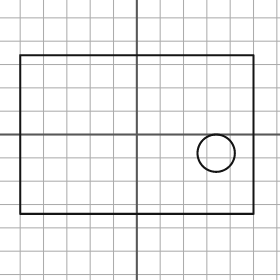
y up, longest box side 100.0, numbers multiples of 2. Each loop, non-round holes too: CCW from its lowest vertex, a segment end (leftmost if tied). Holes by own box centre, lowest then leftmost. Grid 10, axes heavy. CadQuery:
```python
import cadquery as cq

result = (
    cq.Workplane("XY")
    .moveTo(-50.0, -34.0)
    .lineTo(50.0, -34.0)
    .lineTo(50.0, 34.0)
    .lineTo(-50.0, 34.0)
    .close()
    .moveTo(34.0, -8.0)
    .circle(8.0)
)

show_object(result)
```